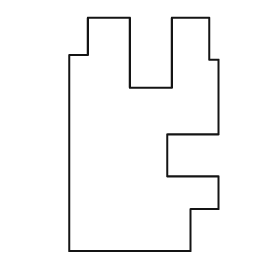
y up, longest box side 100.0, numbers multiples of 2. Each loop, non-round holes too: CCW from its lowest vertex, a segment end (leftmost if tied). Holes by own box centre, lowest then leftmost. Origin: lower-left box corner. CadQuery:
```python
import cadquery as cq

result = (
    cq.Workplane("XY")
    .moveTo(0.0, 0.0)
    .lineTo(52.0, 0.0)
    .lineTo(52.0, 18.0)
    .lineTo(64.0, 18.0)
    .lineTo(64.0, 32.0)
    .lineTo(42.0, 32.0)
    .lineTo(42.0, 50.0)
    .lineTo(64.0, 50.0)
    .lineTo(64.0, 82.0)
    .lineTo(60.0, 82.0)
    .lineTo(60.0, 100.0)
    .lineTo(44.0, 100.0)
    .lineTo(44.0, 70.0)
    .lineTo(26.0, 70.0)
    .lineTo(26.0, 100.0)
    .lineTo(8.0, 100.0)
    .lineTo(8.0, 84.0)
    .lineTo(0.0, 84.0)
    .close()
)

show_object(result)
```